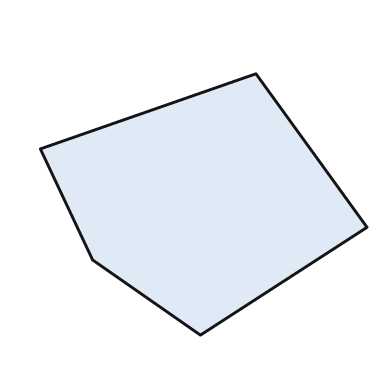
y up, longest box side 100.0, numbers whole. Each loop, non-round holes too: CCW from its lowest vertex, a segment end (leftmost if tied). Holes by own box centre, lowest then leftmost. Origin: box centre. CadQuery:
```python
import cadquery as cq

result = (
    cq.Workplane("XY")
    .moveTo(-1.0, -40.0)
    .lineTo(50.0, -7.0)
    .lineTo(16.0, 40.0)
    .lineTo(-50.0, 17.0)
    .lineTo(-34.0, -17.0)
    .close()
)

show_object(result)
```